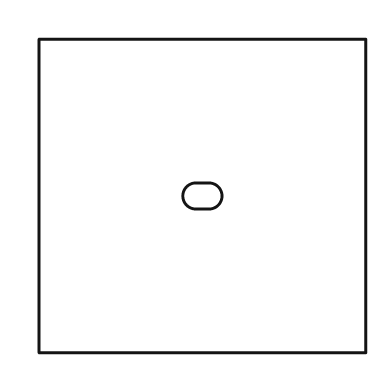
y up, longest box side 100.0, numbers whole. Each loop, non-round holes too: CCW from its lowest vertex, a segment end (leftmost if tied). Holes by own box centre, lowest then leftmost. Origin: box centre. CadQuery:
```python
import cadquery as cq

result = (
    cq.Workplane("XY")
    .moveTo(-50.0, -48.0)
    .lineTo(50.0, -48.0)
    .lineTo(50.0, 48.0)
    .lineTo(-50.0, 48.0)
    .close()
    .moveTo(-2.0, -4.0)
    .lineTo(2.0, -4.0)
    .threePointArc((6.0, 0.0), (2.0, 4.0))
    .lineTo(-2.0, 4.0)
    .threePointArc((-6.0, 0.0), (-2.0, -4.0))
    .close()
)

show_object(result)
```